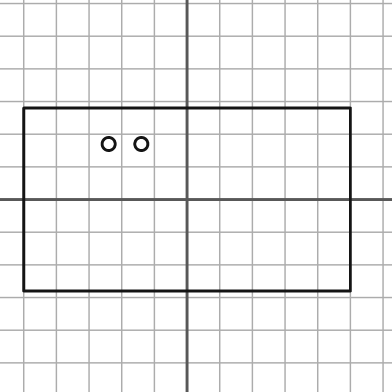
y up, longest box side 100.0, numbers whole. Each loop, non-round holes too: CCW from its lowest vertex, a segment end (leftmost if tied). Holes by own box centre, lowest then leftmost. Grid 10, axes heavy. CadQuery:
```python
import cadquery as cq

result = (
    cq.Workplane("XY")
    .moveTo(-50.0, -28.0)
    .lineTo(50.0, -28.0)
    .lineTo(50.0, 28.0)
    .lineTo(-50.0, 28.0)
    .close()
    .moveTo(-24.0, 17.0)
    .circle(2.0)
    .moveTo(-14.0, 17.0)
    .circle(2.0)
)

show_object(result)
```